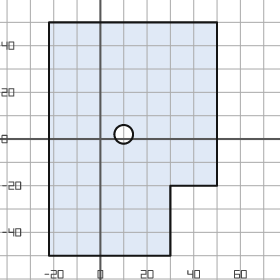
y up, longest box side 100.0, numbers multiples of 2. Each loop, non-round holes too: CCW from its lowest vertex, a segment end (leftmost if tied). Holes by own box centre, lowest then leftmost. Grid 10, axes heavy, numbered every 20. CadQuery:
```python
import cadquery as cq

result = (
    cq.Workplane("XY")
    .moveTo(-22.0, -50.0)
    .lineTo(30.0, -50.0)
    .lineTo(30.0, -20.0)
    .lineTo(50.0, -20.0)
    .lineTo(50.0, 50.0)
    .lineTo(-22.0, 50.0)
    .close()
    .moveTo(10.0, 2.0)
    .circle(4.0)
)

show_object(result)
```